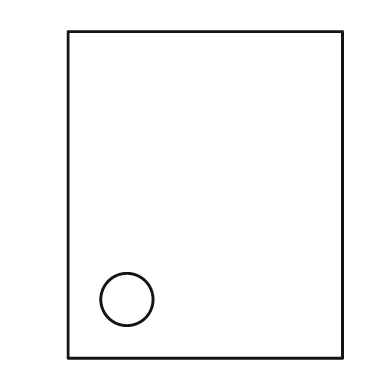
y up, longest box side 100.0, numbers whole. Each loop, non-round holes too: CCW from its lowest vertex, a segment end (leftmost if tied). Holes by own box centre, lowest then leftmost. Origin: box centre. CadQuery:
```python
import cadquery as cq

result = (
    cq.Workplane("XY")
    .moveTo(-42.0, -50.0)
    .lineTo(42.0, -50.0)
    .lineTo(42.0, 50.0)
    .lineTo(-42.0, 50.0)
    .close()
    .moveTo(-24.0, -32.0)
    .circle(8.0)
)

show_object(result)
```